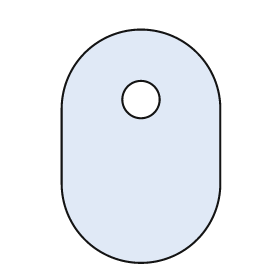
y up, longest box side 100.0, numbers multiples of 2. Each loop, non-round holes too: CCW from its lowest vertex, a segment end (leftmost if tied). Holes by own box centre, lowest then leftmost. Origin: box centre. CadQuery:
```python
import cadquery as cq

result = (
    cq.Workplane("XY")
    .moveTo(-34.0, -16.0)
    .threePointArc((0.0, -50.0), (34.0, -16.0))
    .lineTo(34.0, 16.0)
    .threePointArc((0.0, 50.0), (-34.0, 16.0))
    .close()
    .moveTo(0.0, 20.0)
    .circle(8.0)
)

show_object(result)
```